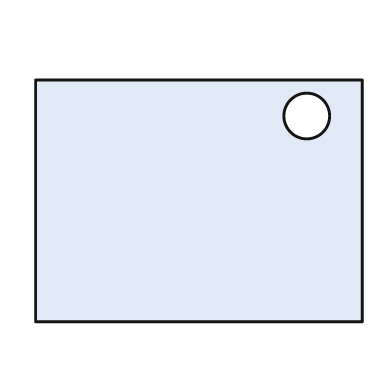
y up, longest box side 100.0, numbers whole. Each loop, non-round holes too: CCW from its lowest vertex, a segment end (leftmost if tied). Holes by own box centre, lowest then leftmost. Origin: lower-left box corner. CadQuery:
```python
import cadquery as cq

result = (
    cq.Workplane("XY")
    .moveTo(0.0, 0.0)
    .lineTo(100.0, 0.0)
    .lineTo(100.0, 74.0)
    .lineTo(0.0, 74.0)
    .close()
    .moveTo(83.0, 63.0)
    .circle(7.0)
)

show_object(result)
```